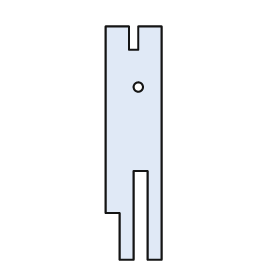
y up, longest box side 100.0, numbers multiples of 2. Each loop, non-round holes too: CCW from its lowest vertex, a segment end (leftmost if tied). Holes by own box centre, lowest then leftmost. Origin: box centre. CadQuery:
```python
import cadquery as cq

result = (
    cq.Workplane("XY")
    .moveTo(-6.0, -50.0)
    .lineTo(0.0, -50.0)
    .lineTo(0.0, -12.0)
    .lineTo(6.0, -12.0)
    .lineTo(6.0, -50.0)
    .lineTo(12.0, -50.0)
    .lineTo(12.0, 50.0)
    .lineTo(2.0, 50.0)
    .lineTo(2.0, 40.0)
    .lineTo(-2.0, 40.0)
    .lineTo(-2.0, 50.0)
    .lineTo(-12.0, 50.0)
    .lineTo(-12.0, -30.0)
    .lineTo(-6.0, -30.0)
    .close()
    .moveTo(2.0, 24.0)
    .circle(2.0)
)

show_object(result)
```